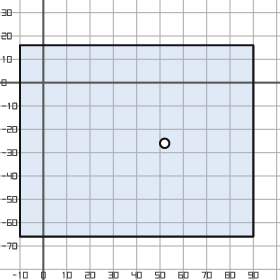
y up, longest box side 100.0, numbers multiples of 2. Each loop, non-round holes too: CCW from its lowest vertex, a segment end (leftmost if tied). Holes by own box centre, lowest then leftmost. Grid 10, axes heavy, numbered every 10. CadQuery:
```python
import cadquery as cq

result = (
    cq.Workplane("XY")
    .moveTo(-10.0, -66.0)
    .lineTo(90.0, -66.0)
    .lineTo(90.0, 16.0)
    .lineTo(-10.0, 16.0)
    .close()
    .moveTo(52.0, -26.0)
    .circle(2.0)
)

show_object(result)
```